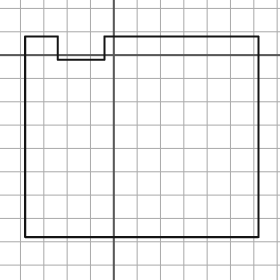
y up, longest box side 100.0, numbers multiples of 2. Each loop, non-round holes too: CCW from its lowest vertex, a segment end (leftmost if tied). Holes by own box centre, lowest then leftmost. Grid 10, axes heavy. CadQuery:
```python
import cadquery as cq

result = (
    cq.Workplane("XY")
    .moveTo(-38.0, -78.0)
    .lineTo(62.0, -78.0)
    .lineTo(62.0, 8.0)
    .lineTo(-4.0, 8.0)
    .lineTo(-4.0, -2.0)
    .lineTo(-24.0, -2.0)
    .lineTo(-24.0, 8.0)
    .lineTo(-38.0, 8.0)
    .close()
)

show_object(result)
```